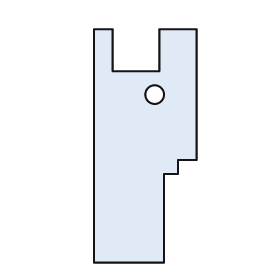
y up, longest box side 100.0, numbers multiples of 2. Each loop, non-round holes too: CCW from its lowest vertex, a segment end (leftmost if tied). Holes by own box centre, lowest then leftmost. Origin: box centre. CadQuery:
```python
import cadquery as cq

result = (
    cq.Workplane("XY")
    .moveTo(-22.0, -50.0)
    .lineTo(8.0, -50.0)
    .lineTo(8.0, -12.0)
    .lineTo(14.0, -12.0)
    .lineTo(14.0, -6.0)
    .lineTo(22.0, -6.0)
    .lineTo(22.0, 50.0)
    .lineTo(6.0, 50.0)
    .lineTo(6.0, 32.0)
    .lineTo(-14.0, 32.0)
    .lineTo(-14.0, 50.0)
    .lineTo(-22.0, 50.0)
    .close()
    .moveTo(4.0, 22.0)
    .circle(4.0)
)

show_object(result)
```